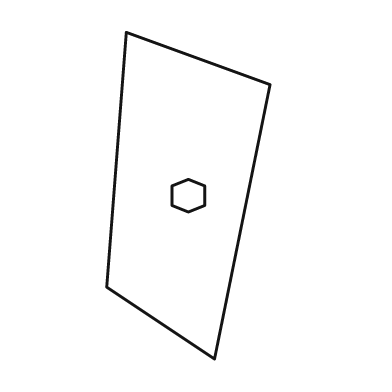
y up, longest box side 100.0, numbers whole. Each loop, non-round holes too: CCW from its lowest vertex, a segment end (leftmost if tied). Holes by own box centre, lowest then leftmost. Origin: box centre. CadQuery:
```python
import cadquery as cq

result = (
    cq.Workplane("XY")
    .moveTo(8.0, -50.0)
    .lineTo(25.0, 34.0)
    .lineTo(-19.0, 50.0)
    .lineTo(-25.0, -28.0)
    .close()
    .moveTo(0.0, -5.0)
    .lineTo(5.0, -3.0)
    .lineTo(5.0, 3.0)
    .lineTo(0.0, 5.0)
    .lineTo(-5.0, 3.0)
    .lineTo(-5.0, -3.0)
    .close()
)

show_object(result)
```